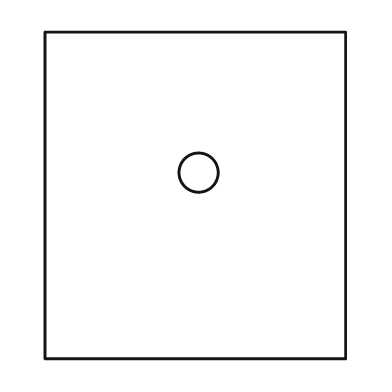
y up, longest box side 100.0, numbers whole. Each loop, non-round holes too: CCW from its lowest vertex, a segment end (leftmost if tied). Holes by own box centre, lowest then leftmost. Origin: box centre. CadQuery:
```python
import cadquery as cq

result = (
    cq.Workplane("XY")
    .moveTo(-46.0, -50.0)
    .lineTo(46.0, -50.0)
    .lineTo(46.0, 50.0)
    .lineTo(-46.0, 50.0)
    .close()
    .moveTo(1.0, 7.0)
    .circle(6.0)
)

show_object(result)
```